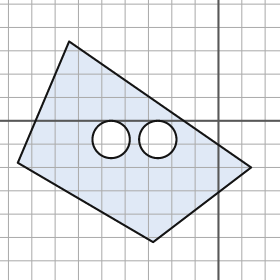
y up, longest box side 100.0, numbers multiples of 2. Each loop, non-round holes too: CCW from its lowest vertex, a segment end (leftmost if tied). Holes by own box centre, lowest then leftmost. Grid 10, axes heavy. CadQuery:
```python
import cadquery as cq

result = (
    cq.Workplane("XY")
    .moveTo(-28.0, -52.0)
    .lineTo(14.0, -20.0)
    .lineTo(-64.0, 34.0)
    .lineTo(-86.0, -18.0)
    .close()
    .moveTo(-46.0, -8.0)
    .circle(8.0)
    .moveTo(-26.0, -8.0)
    .circle(8.0)
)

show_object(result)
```